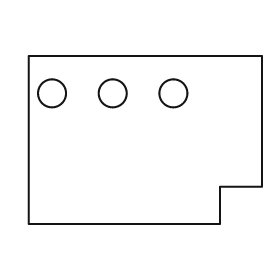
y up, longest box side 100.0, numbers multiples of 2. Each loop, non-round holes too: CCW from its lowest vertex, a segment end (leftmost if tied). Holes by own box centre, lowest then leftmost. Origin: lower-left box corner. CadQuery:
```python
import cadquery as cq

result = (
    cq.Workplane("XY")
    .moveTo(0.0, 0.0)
    .lineTo(82.0, 0.0)
    .lineTo(82.0, 16.0)
    .lineTo(100.0, 16.0)
    .lineTo(100.0, 72.0)
    .lineTo(0.0, 72.0)
    .close()
    .moveTo(10.0, 56.0)
    .circle(6.0)
    .moveTo(36.0, 56.0)
    .circle(6.0)
    .moveTo(62.0, 56.0)
    .circle(6.0)
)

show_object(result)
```